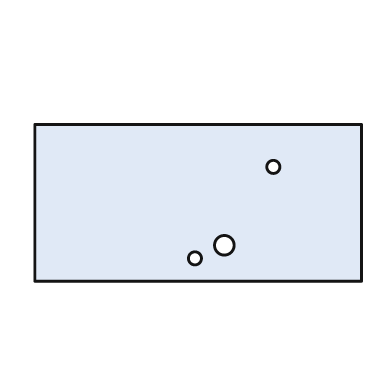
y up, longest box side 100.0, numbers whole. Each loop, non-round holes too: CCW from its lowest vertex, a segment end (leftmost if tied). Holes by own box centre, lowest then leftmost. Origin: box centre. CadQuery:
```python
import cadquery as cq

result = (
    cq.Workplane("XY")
    .moveTo(-50.0, -24.0)
    .lineTo(50.0, -24.0)
    .lineTo(50.0, 24.0)
    .lineTo(-50.0, 24.0)
    .close()
    .moveTo(-1.0, -17.0)
    .circle(2.0)
    .moveTo(8.0, -13.0)
    .circle(3.0)
    .moveTo(23.0, 11.0)
    .circle(2.0)
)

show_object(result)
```